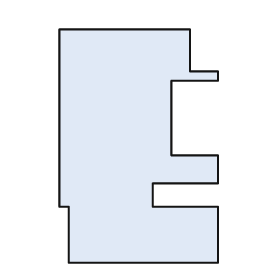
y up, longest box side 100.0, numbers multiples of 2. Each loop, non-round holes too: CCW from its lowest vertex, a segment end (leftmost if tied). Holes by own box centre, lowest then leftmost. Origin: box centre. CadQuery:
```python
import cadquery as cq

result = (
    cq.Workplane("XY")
    .moveTo(-30.0, -50.0)
    .lineTo(34.0, -50.0)
    .lineTo(34.0, -26.0)
    .lineTo(6.0, -26.0)
    .lineTo(6.0, -16.0)
    .lineTo(34.0, -16.0)
    .lineTo(34.0, -4.0)
    .lineTo(14.0, -4.0)
    .lineTo(14.0, 28.0)
    .lineTo(34.0, 28.0)
    .lineTo(34.0, 32.0)
    .lineTo(22.0, 32.0)
    .lineTo(22.0, 50.0)
    .lineTo(-34.0, 50.0)
    .lineTo(-34.0, -26.0)
    .lineTo(-30.0, -26.0)
    .close()
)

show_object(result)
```